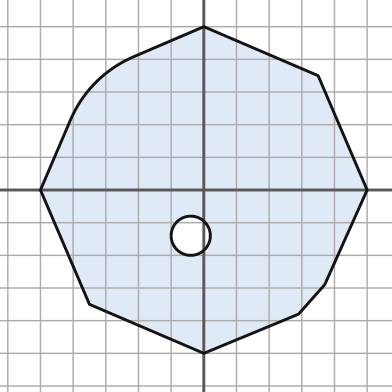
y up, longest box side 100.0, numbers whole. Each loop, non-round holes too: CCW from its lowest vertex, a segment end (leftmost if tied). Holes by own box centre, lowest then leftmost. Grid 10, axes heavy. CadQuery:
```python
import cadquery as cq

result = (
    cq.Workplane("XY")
    .moveTo(0.0, -50.0)
    .lineTo(29.0, -38.0)
    .lineTo(37.0, -29.0)
    .lineTo(50.0, 0.0)
    .lineTo(35.0, 35.0)
    .lineTo(0.0, 50.0)
    .lineTo(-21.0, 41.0)
    .threePointArc((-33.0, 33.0), (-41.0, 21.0))
    .lineTo(-50.0, 0.0)
    .lineTo(-35.0, -35.0)
    .close()
    .moveTo(-4.0, -14.0)
    .circle(6.0)
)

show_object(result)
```